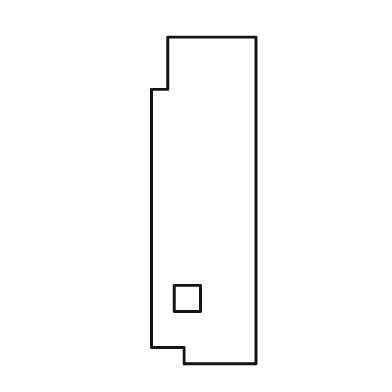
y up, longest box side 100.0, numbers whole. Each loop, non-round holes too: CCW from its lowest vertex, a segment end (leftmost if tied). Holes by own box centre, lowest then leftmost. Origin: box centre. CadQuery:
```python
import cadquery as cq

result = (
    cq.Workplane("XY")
    .moveTo(-6.0, -50.0)
    .lineTo(16.0, -50.0)
    .lineTo(16.0, 50.0)
    .lineTo(-11.0, 50.0)
    .lineTo(-11.0, 34.0)
    .lineTo(-16.0, 34.0)
    .lineTo(-16.0, -45.0)
    .lineTo(-6.0, -45.0)
    .close()
    .moveTo(-9.0, -34.0)
    .lineTo(-1.0, -34.0)
    .lineTo(-1.0, -26.0)
    .lineTo(-9.0, -26.0)
    .close()
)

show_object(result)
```